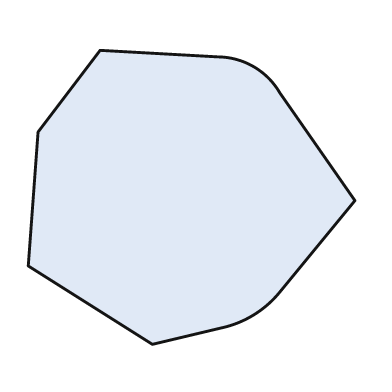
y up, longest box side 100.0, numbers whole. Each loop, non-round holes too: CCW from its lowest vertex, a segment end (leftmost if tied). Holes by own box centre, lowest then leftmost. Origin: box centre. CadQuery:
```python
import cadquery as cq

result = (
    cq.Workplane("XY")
    .moveTo(-12.0, -45.0)
    .lineTo(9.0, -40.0)
    .threePointArc((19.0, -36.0), (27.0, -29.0))
    .lineTo(50.0, -1.0)
    .lineTo(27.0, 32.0)
    .threePointArc((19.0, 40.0), (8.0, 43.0))
    .lineTo(-28.0, 45.0)
    .lineTo(-47.0, 20.0)
    .lineTo(-50.0, -21.0)
    .close()
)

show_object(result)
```